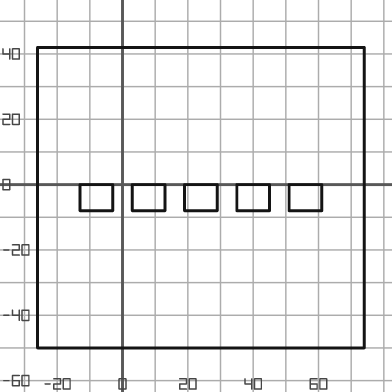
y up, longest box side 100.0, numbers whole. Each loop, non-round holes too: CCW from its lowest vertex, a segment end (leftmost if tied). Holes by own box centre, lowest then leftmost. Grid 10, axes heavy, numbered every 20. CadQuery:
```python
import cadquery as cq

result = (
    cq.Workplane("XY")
    .moveTo(-26.0, -50.0)
    .lineTo(74.0, -50.0)
    .lineTo(74.0, 42.0)
    .lineTo(-26.0, 42.0)
    .close()
    .moveTo(-13.0, -8.0)
    .lineTo(-3.0, -8.0)
    .lineTo(-3.0, 0.0)
    .lineTo(-13.0, 0.0)
    .close()
    .moveTo(3.0, -8.0)
    .lineTo(13.0, -8.0)
    .lineTo(13.0, 0.0)
    .lineTo(3.0, 0.0)
    .close()
    .moveTo(19.0, -8.0)
    .lineTo(29.0, -8.0)
    .lineTo(29.0, 0.0)
    .lineTo(19.0, 0.0)
    .close()
    .moveTo(35.0, -8.0)
    .lineTo(45.0, -8.0)
    .lineTo(45.0, 0.0)
    .lineTo(35.0, 0.0)
    .close()
    .moveTo(51.0, -8.0)
    .lineTo(61.0, -8.0)
    .lineTo(61.0, 0.0)
    .lineTo(51.0, 0.0)
    .close()
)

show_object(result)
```